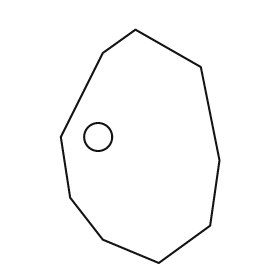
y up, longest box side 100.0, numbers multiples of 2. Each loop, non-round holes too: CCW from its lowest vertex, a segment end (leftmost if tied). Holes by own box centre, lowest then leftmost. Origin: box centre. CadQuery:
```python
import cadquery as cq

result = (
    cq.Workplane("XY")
    .moveTo(8.0, -50.0)
    .lineTo(30.0, -34.0)
    .lineTo(34.0, -6.0)
    .lineTo(26.0, 34.0)
    .lineTo(-2.0, 50.0)
    .lineTo(-16.0, 40.0)
    .lineTo(-34.0, 4.0)
    .lineTo(-30.0, -22.0)
    .lineTo(-16.0, -40.0)
    .close()
    .moveTo(-18.0, 4.0)
    .circle(6.0)
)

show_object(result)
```